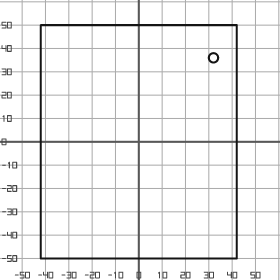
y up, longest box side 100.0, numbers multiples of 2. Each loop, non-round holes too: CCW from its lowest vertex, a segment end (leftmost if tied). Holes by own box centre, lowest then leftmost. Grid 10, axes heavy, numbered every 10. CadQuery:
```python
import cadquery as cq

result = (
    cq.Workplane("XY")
    .moveTo(-42.0, -50.0)
    .lineTo(42.0, -50.0)
    .lineTo(42.0, 50.0)
    .lineTo(-42.0, 50.0)
    .close()
    .moveTo(32.0, 36.0)
    .circle(2.0)
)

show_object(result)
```